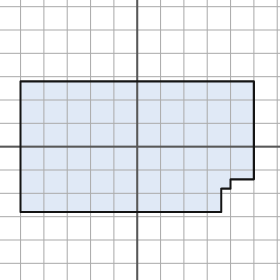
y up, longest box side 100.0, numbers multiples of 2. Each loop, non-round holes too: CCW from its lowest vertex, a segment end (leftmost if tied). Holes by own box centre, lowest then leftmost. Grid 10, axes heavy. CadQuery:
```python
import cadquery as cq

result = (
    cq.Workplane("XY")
    .moveTo(-50.0, -28.0)
    .lineTo(36.0, -28.0)
    .lineTo(36.0, -18.0)
    .lineTo(40.0, -18.0)
    .lineTo(40.0, -14.0)
    .lineTo(50.0, -14.0)
    .lineTo(50.0, 28.0)
    .lineTo(-50.0, 28.0)
    .close()
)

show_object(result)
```